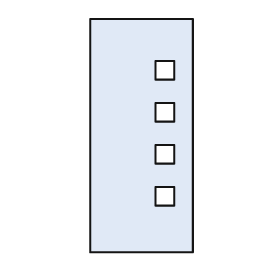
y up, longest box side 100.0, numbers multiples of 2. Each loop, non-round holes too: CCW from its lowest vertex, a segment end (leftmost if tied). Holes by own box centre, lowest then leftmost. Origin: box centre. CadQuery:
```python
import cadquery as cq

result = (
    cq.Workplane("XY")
    .moveTo(-22.0, -50.0)
    .lineTo(22.0, -50.0)
    .lineTo(22.0, 50.0)
    .lineTo(-22.0, 50.0)
    .close()
    .moveTo(6.0, -30.0)
    .lineTo(14.0, -30.0)
    .lineTo(14.0, -22.0)
    .lineTo(6.0, -22.0)
    .close()
    .moveTo(6.0, -12.0)
    .lineTo(14.0, -12.0)
    .lineTo(14.0, -4.0)
    .lineTo(6.0, -4.0)
    .close()
    .moveTo(6.0, 6.0)
    .lineTo(14.0, 6.0)
    .lineTo(14.0, 14.0)
    .lineTo(6.0, 14.0)
    .close()
    .moveTo(6.0, 24.0)
    .lineTo(14.0, 24.0)
    .lineTo(14.0, 32.0)
    .lineTo(6.0, 32.0)
    .close()
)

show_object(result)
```